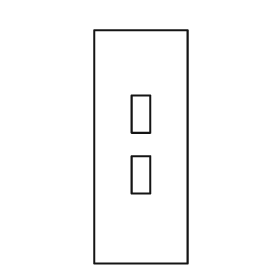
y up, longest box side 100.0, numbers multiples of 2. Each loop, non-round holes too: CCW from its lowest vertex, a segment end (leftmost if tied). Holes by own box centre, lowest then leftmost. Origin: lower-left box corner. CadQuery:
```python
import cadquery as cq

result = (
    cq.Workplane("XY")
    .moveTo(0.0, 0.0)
    .lineTo(40.0, 0.0)
    .lineTo(40.0, 100.0)
    .lineTo(0.0, 100.0)
    .close()
    .moveTo(16.0, 30.0)
    .lineTo(24.0, 30.0)
    .lineTo(24.0, 46.0)
    .lineTo(16.0, 46.0)
    .close()
    .moveTo(16.0, 56.0)
    .lineTo(24.0, 56.0)
    .lineTo(24.0, 72.0)
    .lineTo(16.0, 72.0)
    .close()
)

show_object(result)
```